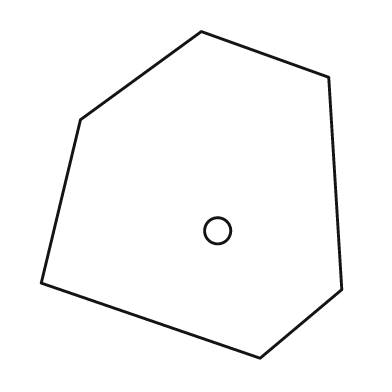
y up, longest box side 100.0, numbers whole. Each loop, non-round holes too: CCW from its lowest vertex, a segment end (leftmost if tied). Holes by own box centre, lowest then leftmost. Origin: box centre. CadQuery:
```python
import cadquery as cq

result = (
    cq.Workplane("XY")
    .moveTo(21.0, -50.0)
    .lineTo(46.0, -29.0)
    .lineTo(42.0, 36.0)
    .lineTo(3.0, 50.0)
    .lineTo(-34.0, 23.0)
    .lineTo(-46.0, -27.0)
    .close()
    .moveTo(8.0, -11.0)
    .circle(4.0)
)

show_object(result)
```